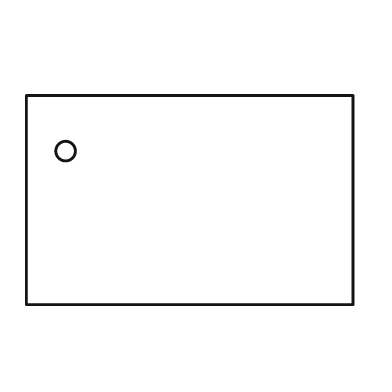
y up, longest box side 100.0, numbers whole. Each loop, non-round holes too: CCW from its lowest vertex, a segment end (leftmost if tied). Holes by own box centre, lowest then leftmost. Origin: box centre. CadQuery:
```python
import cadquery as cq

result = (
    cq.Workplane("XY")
    .moveTo(-50.0, -32.0)
    .lineTo(50.0, -32.0)
    .lineTo(50.0, 32.0)
    .lineTo(-50.0, 32.0)
    .close()
    .moveTo(-38.0, 15.0)
    .circle(3.0)
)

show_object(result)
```